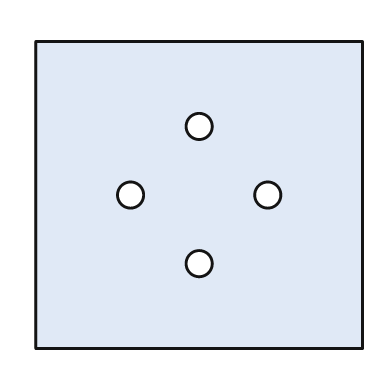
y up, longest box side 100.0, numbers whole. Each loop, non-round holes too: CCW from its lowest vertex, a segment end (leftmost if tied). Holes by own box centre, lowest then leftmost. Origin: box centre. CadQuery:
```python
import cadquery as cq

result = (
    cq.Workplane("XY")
    .moveTo(-50.0, -47.0)
    .lineTo(50.0, -47.0)
    .lineTo(50.0, 47.0)
    .lineTo(-50.0, 47.0)
    .close()
    .moveTo(0.0, -21.0)
    .circle(4.0)
    .moveTo(-21.0, 0.0)
    .circle(4.0)
    .moveTo(21.0, 0.0)
    .circle(4.0)
    .moveTo(0.0, 21.0)
    .circle(4.0)
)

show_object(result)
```